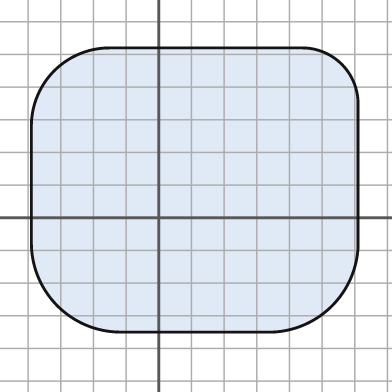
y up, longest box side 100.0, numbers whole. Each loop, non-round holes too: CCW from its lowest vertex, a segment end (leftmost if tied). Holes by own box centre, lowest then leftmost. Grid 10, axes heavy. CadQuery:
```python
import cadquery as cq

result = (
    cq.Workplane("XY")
    .moveTo(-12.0, -35.0)
    .lineTo(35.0, -35.0)
    .threePointArc((53.0, -27.0), (61.0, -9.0))
    .lineTo(61.0, 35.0)
    .threePointArc((56.0, 47.0), (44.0, 52.0))
    .lineTo(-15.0, 52.0)
    .threePointArc((-32.0, 45.0), (-39.0, 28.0))
    .lineTo(-39.0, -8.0)
    .threePointArc((-31.0, -27.0), (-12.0, -35.0))
    .close()
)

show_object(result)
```